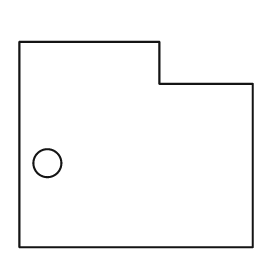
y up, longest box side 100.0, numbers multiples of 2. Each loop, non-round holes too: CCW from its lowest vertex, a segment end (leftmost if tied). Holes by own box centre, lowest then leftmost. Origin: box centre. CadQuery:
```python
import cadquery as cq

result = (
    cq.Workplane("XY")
    .moveTo(-50.0, -44.0)
    .lineTo(50.0, -44.0)
    .lineTo(50.0, 26.0)
    .lineTo(10.0, 26.0)
    .lineTo(10.0, 44.0)
    .lineTo(-50.0, 44.0)
    .close()
    .moveTo(-38.0, -8.0)
    .circle(6.0)
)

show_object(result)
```